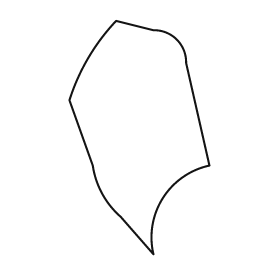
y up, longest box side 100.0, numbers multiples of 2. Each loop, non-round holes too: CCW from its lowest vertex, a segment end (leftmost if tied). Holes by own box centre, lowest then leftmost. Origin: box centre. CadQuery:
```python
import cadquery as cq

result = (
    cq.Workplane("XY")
    .moveTo(6.0, -50.0)
    .threePointArc((10.0, -26.0), (30.0, -12.0))
    .lineTo(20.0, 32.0)
    .threePointArc((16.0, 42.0), (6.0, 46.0))
    .lineTo(-10.0, 50.0)
    .threePointArc((-22.0, 34.0), (-30.0, 16.0))
    .lineTo(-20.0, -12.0)
    .threePointArc((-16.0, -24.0), (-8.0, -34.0))
    .close()
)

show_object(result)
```